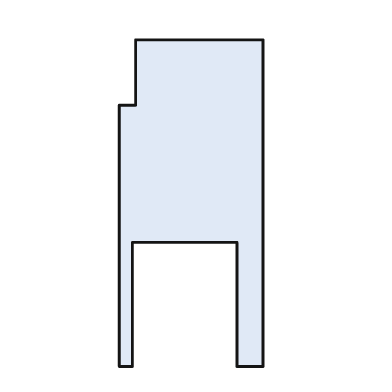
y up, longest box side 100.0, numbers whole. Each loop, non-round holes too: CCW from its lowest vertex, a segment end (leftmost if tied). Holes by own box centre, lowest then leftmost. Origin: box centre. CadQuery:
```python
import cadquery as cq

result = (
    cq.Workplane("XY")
    .moveTo(-22.0, -50.0)
    .lineTo(-18.0, -50.0)
    .lineTo(-18.0, -12.0)
    .lineTo(14.0, -12.0)
    .lineTo(14.0, -50.0)
    .lineTo(22.0, -50.0)
    .lineTo(22.0, 50.0)
    .lineTo(-17.0, 50.0)
    .lineTo(-17.0, 30.0)
    .lineTo(-22.0, 30.0)
    .close()
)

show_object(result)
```